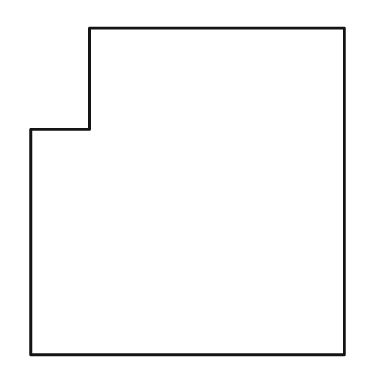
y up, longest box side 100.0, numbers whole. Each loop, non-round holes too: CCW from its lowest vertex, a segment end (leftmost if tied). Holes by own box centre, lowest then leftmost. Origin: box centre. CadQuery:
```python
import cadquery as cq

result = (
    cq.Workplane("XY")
    .moveTo(-48.0, -50.0)
    .lineTo(48.0, -50.0)
    .lineTo(48.0, 50.0)
    .lineTo(-30.0, 50.0)
    .lineTo(-30.0, 19.0)
    .lineTo(-48.0, 19.0)
    .close()
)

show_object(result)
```